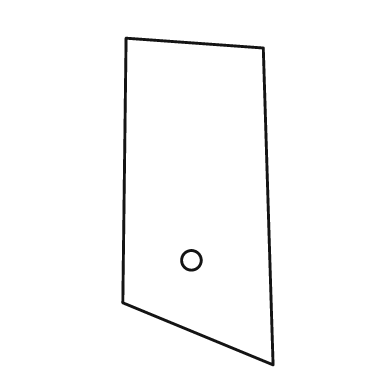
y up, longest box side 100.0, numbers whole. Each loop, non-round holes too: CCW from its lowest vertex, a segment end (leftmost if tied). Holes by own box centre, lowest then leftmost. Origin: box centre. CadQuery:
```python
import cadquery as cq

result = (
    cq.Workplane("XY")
    .moveTo(23.0, -50.0)
    .lineTo(20.0, 47.0)
    .lineTo(-22.0, 50.0)
    .lineTo(-23.0, -31.0)
    .close()
    .moveTo(-2.0, -18.0)
    .circle(3.0)
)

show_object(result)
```